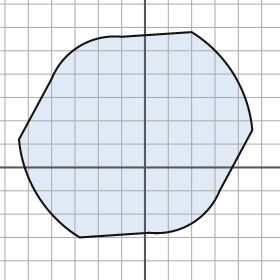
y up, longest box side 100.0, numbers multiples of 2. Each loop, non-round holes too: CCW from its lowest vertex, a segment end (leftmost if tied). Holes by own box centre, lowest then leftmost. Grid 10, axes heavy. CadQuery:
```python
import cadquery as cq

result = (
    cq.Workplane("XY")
    .moveTo(-28.0, -30.0)
    .lineTo(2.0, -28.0)
    .threePointArc((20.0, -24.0), (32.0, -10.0))
    .lineTo(46.0, 16.0)
    .threePointArc((38.0, 40.0), (20.0, 58.0))
    .lineTo(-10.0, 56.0)
    .threePointArc((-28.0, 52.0), (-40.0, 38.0))
    .lineTo(-54.0, 12.0)
    .threePointArc((-46.0, -12.0), (-28.0, -30.0))
    .close()
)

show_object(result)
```